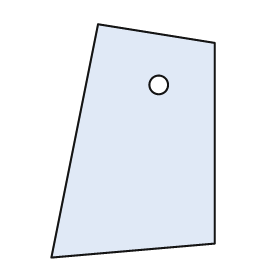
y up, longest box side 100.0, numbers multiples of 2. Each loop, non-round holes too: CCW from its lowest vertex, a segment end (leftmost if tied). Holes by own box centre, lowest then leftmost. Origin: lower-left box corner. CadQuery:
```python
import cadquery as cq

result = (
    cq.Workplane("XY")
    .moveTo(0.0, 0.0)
    .lineTo(70.0, 6.0)
    .lineTo(70.0, 92.0)
    .lineTo(20.0, 100.0)
    .close()
    .moveTo(46.0, 74.0)
    .circle(4.0)
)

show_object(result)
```